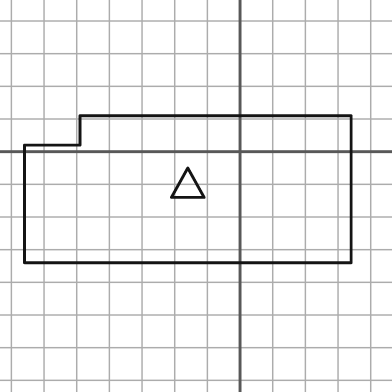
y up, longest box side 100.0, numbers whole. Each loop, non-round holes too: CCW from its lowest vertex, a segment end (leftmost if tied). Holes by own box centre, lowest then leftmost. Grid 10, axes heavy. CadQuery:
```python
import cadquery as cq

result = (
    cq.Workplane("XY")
    .moveTo(-66.0, -34.0)
    .lineTo(34.0, -34.0)
    .lineTo(34.0, 11.0)
    .lineTo(-49.0, 11.0)
    .lineTo(-49.0, 2.0)
    .lineTo(-66.0, 2.0)
    .close()
    .moveTo(-21.0, -14.0)
    .lineTo(-11.0, -14.0)
    .lineTo(-16.0, -5.0)
    .close()
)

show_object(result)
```